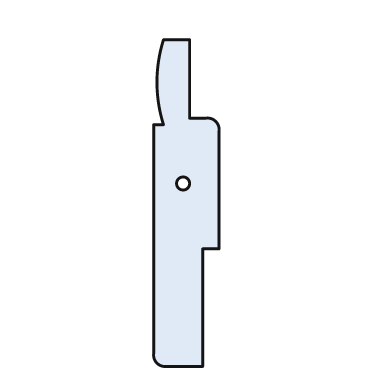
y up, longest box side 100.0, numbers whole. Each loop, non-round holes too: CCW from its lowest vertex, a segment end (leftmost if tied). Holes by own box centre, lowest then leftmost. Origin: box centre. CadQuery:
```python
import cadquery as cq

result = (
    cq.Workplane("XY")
    .moveTo(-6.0, -50.0)
    .lineTo(5.0, -50.0)
    .lineTo(5.0, -14.0)
    .lineTo(10.0, -14.0)
    .lineTo(10.0, 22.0)
    .threePointArc((9.0, 25.0), (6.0, 26.0))
    .lineTo(1.0, 26.0)
    .lineTo(1.0, 50.0)
    .lineTo(-7.0, 50.0)
    .threePointArc((-9.0, 37.0), (-7.0, 24.0))
    .lineTo(-10.0, 24.0)
    .lineTo(-10.0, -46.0)
    .threePointArc((-9.0, -49.0), (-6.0, -50.0))
    .close()
    .moveTo(-1.0, 6.0)
    .circle(2.0)
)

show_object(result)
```